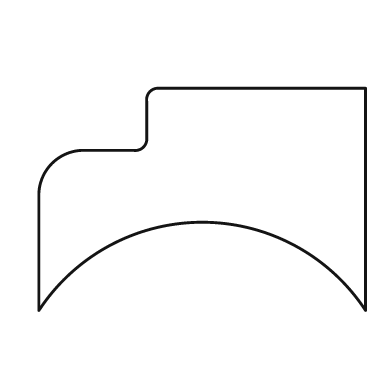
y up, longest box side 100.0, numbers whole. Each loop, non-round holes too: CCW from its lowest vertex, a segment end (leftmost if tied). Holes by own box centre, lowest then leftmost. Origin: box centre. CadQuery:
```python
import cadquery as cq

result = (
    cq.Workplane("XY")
    .moveTo(-50.0, -34.0)
    .threePointArc((0.0, -7.0), (50.0, -34.0))
    .lineTo(50.0, 34.0)
    .lineTo(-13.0, 34.0)
    .threePointArc((-16.0, 33.0), (-17.0, 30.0))
    .lineTo(-17.0, 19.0)
    .threePointArc((-18.0, 16.0), (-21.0, 15.0))
    .lineTo(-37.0, 15.0)
    .threePointArc((-46.0, 11.0), (-50.0, 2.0))
    .close()
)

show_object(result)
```